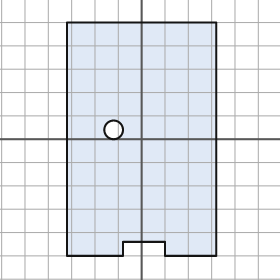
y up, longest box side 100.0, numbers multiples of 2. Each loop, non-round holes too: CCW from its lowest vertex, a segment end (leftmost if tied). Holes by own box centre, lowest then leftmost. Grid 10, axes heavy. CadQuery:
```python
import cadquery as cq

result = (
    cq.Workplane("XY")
    .moveTo(-32.0, -50.0)
    .lineTo(-8.0, -50.0)
    .lineTo(-8.0, -44.0)
    .lineTo(10.0, -44.0)
    .lineTo(10.0, -50.0)
    .lineTo(32.0, -50.0)
    .lineTo(32.0, 50.0)
    .lineTo(-32.0, 50.0)
    .close()
    .moveTo(-12.0, 4.0)
    .circle(4.0)
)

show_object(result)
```